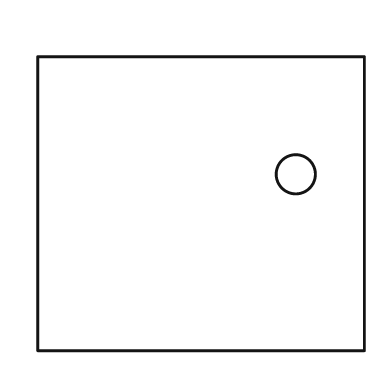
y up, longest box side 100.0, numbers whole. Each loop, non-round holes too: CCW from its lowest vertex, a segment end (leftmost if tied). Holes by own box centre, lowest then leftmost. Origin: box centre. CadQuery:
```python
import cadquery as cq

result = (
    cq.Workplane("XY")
    .moveTo(-50.0, -45.0)
    .lineTo(50.0, -45.0)
    .lineTo(50.0, 45.0)
    .lineTo(-50.0, 45.0)
    .close()
    .moveTo(29.0, 9.0)
    .circle(6.0)
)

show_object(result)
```